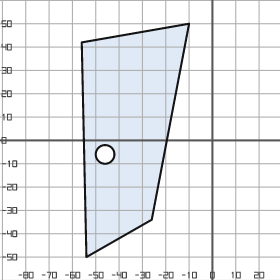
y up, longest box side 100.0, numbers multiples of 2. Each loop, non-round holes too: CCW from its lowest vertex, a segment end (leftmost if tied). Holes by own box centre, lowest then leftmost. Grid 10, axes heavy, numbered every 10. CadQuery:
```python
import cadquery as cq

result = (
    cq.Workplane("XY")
    .moveTo(-54.0, -50.0)
    .lineTo(-26.0, -34.0)
    .lineTo(-10.0, 50.0)
    .lineTo(-56.0, 42.0)
    .close()
    .moveTo(-46.0, -6.0)
    .circle(4.0)
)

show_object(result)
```